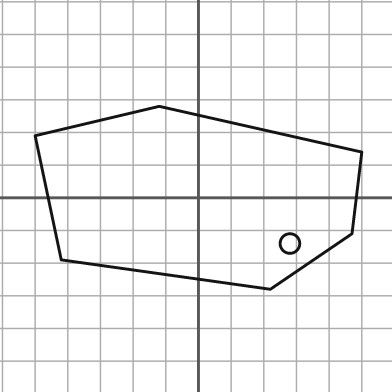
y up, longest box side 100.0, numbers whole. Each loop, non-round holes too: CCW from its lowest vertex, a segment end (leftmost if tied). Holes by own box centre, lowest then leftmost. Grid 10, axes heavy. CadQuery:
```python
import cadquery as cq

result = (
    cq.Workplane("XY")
    .moveTo(22.0, -28.0)
    .lineTo(47.0, -11.0)
    .lineTo(50.0, 14.0)
    .lineTo(-12.0, 28.0)
    .lineTo(-50.0, 19.0)
    .lineTo(-42.0, -19.0)
    .close()
    .moveTo(28.0, -14.0)
    .circle(3.0)
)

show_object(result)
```